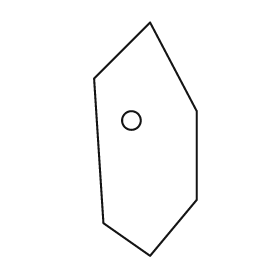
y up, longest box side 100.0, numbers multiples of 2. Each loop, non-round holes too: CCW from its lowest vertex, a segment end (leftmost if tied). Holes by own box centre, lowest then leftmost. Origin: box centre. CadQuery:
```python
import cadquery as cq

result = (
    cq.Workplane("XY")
    .moveTo(2.0, -50.0)
    .lineTo(22.0, -26.0)
    .lineTo(22.0, 12.0)
    .lineTo(2.0, 50.0)
    .lineTo(-22.0, 26.0)
    .lineTo(-18.0, -36.0)
    .close()
    .moveTo(-6.0, 8.0)
    .circle(4.0)
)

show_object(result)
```